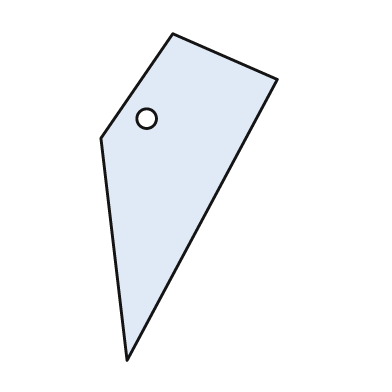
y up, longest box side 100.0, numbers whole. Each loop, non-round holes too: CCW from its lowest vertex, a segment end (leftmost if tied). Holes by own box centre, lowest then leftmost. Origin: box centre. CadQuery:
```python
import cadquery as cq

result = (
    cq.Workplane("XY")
    .moveTo(-19.0, -50.0)
    .lineTo(27.0, 36.0)
    .lineTo(-5.0, 50.0)
    .lineTo(-27.0, 18.0)
    .close()
    .moveTo(-13.0, 24.0)
    .circle(3.0)
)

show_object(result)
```